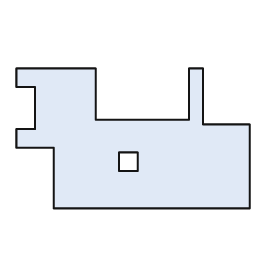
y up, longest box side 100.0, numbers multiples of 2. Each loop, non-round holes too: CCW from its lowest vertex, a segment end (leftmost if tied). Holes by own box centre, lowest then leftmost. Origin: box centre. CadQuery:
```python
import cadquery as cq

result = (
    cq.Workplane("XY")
    .moveTo(-34.0, -30.0)
    .lineTo(50.0, -30.0)
    .lineTo(50.0, 6.0)
    .lineTo(30.0, 6.0)
    .lineTo(30.0, 30.0)
    .lineTo(24.0, 30.0)
    .lineTo(24.0, 8.0)
    .lineTo(-16.0, 8.0)
    .lineTo(-16.0, 30.0)
    .lineTo(-50.0, 30.0)
    .lineTo(-50.0, 22.0)
    .lineTo(-42.0, 22.0)
    .lineTo(-42.0, 4.0)
    .lineTo(-50.0, 4.0)
    .lineTo(-50.0, -4.0)
    .lineTo(-34.0, -4.0)
    .close()
    .moveTo(-6.0, -14.0)
    .lineTo(2.0, -14.0)
    .lineTo(2.0, -6.0)
    .lineTo(-6.0, -6.0)
    .close()
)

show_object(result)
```